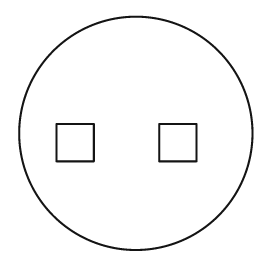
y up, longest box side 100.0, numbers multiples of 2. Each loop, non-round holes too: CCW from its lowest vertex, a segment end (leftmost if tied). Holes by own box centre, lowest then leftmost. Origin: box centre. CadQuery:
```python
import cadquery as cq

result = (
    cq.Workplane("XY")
    .moveTo(0.0, 0.0)
    .circle(50.0)
    .moveTo(-34.0, -12.0)
    .lineTo(-18.0, -12.0)
    .lineTo(-18.0, 4.0)
    .lineTo(-34.0, 4.0)
    .close()
    .moveTo(10.0, -12.0)
    .lineTo(26.0, -12.0)
    .lineTo(26.0, 4.0)
    .lineTo(10.0, 4.0)
    .close()
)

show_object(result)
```